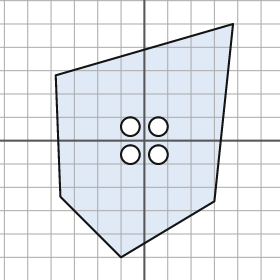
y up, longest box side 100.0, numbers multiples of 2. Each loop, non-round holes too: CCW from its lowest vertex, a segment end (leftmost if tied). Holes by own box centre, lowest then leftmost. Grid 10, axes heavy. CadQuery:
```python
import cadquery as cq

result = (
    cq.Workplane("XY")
    .moveTo(-10.0, -50.0)
    .lineTo(30.0, -26.0)
    .lineTo(38.0, 50.0)
    .lineTo(-38.0, 28.0)
    .lineTo(-36.0, -24.0)
    .close()
    .moveTo(-6.0, -6.0)
    .circle(4.0)
    .moveTo(6.0, -6.0)
    .circle(4.0)
    .moveTo(-6.0, 6.0)
    .circle(4.0)
    .moveTo(6.0, 6.0)
    .circle(4.0)
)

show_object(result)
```